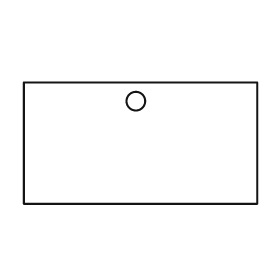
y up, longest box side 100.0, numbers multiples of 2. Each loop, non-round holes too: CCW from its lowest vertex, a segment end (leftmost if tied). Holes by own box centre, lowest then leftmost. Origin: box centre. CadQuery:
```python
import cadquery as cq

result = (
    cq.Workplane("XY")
    .moveTo(-50.0, -26.0)
    .lineTo(50.0, -26.0)
    .lineTo(50.0, 26.0)
    .lineTo(-50.0, 26.0)
    .close()
    .moveTo(-2.0, 18.0)
    .circle(4.0)
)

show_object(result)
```